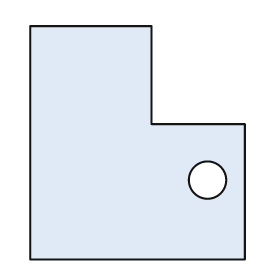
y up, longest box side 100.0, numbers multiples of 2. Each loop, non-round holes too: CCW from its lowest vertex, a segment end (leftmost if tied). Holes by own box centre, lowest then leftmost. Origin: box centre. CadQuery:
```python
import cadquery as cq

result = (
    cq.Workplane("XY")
    .moveTo(-46.0, -50.0)
    .lineTo(46.0, -50.0)
    .lineTo(46.0, 8.0)
    .lineTo(6.0, 8.0)
    .lineTo(6.0, 50.0)
    .lineTo(-46.0, 50.0)
    .close()
    .moveTo(30.0, -16.0)
    .circle(8.0)
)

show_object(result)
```